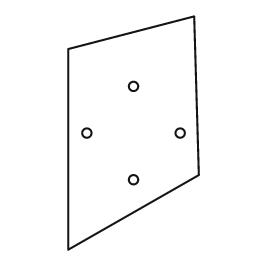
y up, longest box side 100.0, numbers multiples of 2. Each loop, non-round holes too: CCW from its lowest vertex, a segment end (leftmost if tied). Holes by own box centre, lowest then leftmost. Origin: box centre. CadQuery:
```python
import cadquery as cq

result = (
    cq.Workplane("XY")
    .moveTo(-28.0, -50.0)
    .lineTo(28.0, -18.0)
    .lineTo(26.0, 50.0)
    .lineTo(-28.0, 36.0)
    .close()
    .moveTo(0.0, -20.0)
    .circle(2.0)
    .moveTo(-20.0, 0.0)
    .circle(2.0)
    .moveTo(20.0, 0.0)
    .circle(2.0)
    .moveTo(0.0, 20.0)
    .circle(2.0)
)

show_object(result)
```